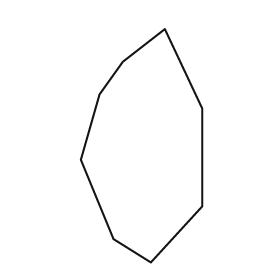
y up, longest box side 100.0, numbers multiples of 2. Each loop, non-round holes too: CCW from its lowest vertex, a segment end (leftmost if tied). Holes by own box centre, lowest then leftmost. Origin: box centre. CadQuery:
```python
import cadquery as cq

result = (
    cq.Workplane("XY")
    .moveTo(4.0, -50.0)
    .lineTo(26.0, -26.0)
    .lineTo(26.0, 16.0)
    .lineTo(10.0, 50.0)
    .lineTo(-8.0, 36.0)
    .lineTo(-18.0, 22.0)
    .lineTo(-26.0, -6.0)
    .lineTo(-12.0, -40.0)
    .close()
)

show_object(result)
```